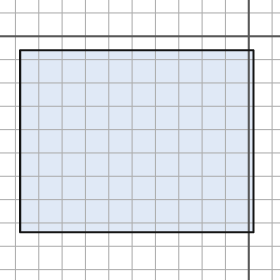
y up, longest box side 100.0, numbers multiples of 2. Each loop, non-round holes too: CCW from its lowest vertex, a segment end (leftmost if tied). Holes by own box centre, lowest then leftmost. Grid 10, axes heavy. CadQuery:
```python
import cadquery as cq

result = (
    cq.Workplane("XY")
    .moveTo(-98.0, -84.0)
    .lineTo(2.0, -84.0)
    .lineTo(2.0, -6.0)
    .lineTo(-98.0, -6.0)
    .close()
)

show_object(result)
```